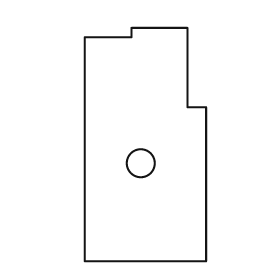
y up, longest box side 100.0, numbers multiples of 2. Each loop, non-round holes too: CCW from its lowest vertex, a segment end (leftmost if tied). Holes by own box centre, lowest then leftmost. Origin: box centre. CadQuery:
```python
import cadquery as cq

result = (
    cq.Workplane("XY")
    .moveTo(-26.0, -50.0)
    .lineTo(26.0, -50.0)
    .lineTo(26.0, 16.0)
    .lineTo(18.0, 16.0)
    .lineTo(18.0, 50.0)
    .lineTo(-6.0, 50.0)
    .lineTo(-6.0, 46.0)
    .lineTo(-26.0, 46.0)
    .close()
    .moveTo(-2.0, -8.0)
    .circle(6.0)
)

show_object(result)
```